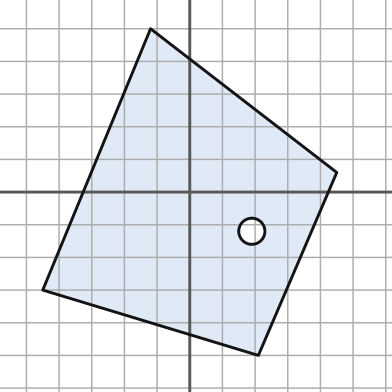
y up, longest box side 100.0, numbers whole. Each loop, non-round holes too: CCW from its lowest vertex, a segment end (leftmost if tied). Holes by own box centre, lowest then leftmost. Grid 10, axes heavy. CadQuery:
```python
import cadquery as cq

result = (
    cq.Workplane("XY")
    .moveTo(21.0, -50.0)
    .lineTo(45.0, 6.0)
    .lineTo(-12.0, 50.0)
    .lineTo(-45.0, -30.0)
    .close()
    .moveTo(19.0, -12.0)
    .circle(4.0)
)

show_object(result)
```